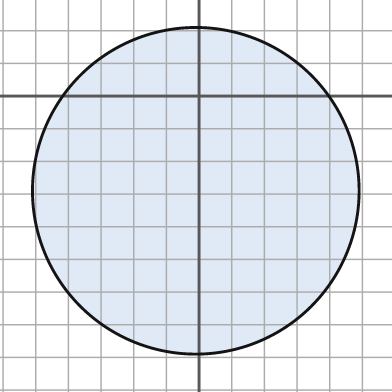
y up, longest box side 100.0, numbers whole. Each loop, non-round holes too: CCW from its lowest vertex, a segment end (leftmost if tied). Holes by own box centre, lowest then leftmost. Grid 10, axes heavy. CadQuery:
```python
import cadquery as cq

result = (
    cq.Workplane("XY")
    .moveTo(-1.0, -29.0)
    .circle(50.0)
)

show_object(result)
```